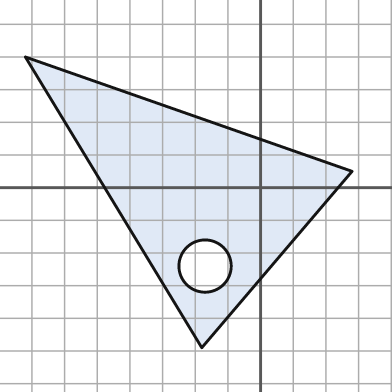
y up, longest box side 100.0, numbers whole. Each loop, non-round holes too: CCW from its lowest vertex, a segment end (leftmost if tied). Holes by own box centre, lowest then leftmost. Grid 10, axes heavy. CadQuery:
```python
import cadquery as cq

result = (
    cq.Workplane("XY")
    .moveTo(-18.0, -49.0)
    .lineTo(28.0, 5.0)
    .lineTo(-72.0, 40.0)
    .close()
    .moveTo(-17.0, -24.0)
    .circle(8.0)
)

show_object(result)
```